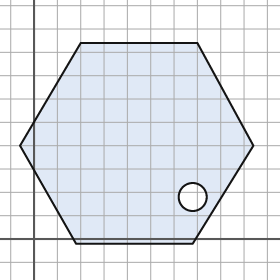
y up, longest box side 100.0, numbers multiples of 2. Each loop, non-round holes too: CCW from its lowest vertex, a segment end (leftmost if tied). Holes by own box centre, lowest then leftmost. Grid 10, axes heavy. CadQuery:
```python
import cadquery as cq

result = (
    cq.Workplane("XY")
    .moveTo(18.0, -2.0)
    .lineTo(68.0, -2.0)
    .lineTo(94.0, 40.0)
    .lineTo(70.0, 84.0)
    .lineTo(20.0, 84.0)
    .lineTo(-6.0, 40.0)
    .close()
    .moveTo(68.0, 18.0)
    .circle(6.0)
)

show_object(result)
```